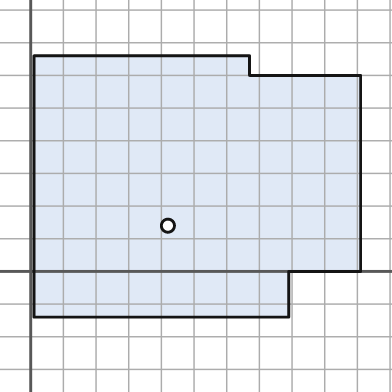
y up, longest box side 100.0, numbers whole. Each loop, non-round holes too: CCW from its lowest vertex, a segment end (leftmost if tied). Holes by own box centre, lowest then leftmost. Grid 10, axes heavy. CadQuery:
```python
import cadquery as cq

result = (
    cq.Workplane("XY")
    .moveTo(1.0, -14.0)
    .lineTo(79.0, -14.0)
    .lineTo(79.0, 0.0)
    .lineTo(101.0, 0.0)
    .lineTo(101.0, 60.0)
    .lineTo(67.0, 60.0)
    .lineTo(67.0, 66.0)
    .lineTo(1.0, 66.0)
    .close()
    .moveTo(42.0, 14.0)
    .circle(2.0)
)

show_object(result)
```